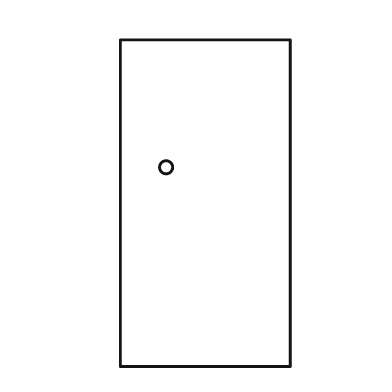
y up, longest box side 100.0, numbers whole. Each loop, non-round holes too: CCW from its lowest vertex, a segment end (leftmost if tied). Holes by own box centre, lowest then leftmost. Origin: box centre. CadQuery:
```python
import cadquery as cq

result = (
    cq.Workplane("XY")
    .moveTo(-26.0, -50.0)
    .lineTo(26.0, -50.0)
    .lineTo(26.0, 50.0)
    .lineTo(-26.0, 50.0)
    .close()
    .moveTo(-12.0, 11.0)
    .circle(2.0)
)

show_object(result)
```